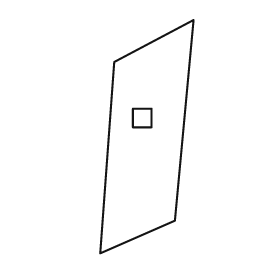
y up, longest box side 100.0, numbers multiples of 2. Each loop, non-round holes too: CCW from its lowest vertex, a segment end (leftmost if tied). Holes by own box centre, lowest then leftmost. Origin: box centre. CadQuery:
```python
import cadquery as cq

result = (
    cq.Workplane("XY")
    .moveTo(-20.0, -50.0)
    .lineTo(12.0, -36.0)
    .lineTo(20.0, 50.0)
    .lineTo(-14.0, 32.0)
    .close()
    .moveTo(-6.0, 4.0)
    .lineTo(2.0, 4.0)
    .lineTo(2.0, 12.0)
    .lineTo(-6.0, 12.0)
    .close()
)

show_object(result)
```